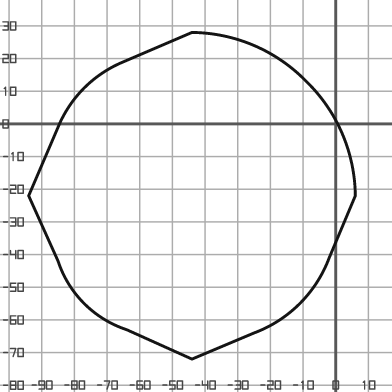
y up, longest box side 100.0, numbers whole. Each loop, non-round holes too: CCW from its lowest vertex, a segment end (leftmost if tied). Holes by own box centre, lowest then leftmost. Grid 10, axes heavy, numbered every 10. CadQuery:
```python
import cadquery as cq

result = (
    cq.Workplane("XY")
    .moveTo(-44.0, -72.0)
    .lineTo(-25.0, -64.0)
    .threePointArc((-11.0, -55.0), (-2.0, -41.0))
    .lineTo(6.0, -22.0)
    .threePointArc((2.0, -3.0), (-9.0, 13.0))
    .threePointArc((-25.0, 24.0), (-44.0, 28.0))
    .lineTo(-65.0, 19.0)
    .threePointArc((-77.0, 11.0), (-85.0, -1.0))
    .lineTo(-94.0, -22.0)
    .lineTo(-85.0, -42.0)
    .threePointArc((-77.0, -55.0), (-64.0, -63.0))
    .close()
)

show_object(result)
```